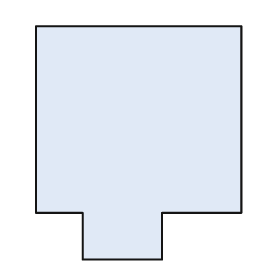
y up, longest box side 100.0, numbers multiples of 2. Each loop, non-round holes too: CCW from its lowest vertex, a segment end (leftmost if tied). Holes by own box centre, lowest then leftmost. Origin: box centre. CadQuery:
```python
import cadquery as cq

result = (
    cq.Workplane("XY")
    .moveTo(-24.0, -50.0)
    .lineTo(10.0, -50.0)
    .lineTo(10.0, -30.0)
    .lineTo(44.0, -30.0)
    .lineTo(44.0, 50.0)
    .lineTo(-44.0, 50.0)
    .lineTo(-44.0, -30.0)
    .lineTo(-24.0, -30.0)
    .close()
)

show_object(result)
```